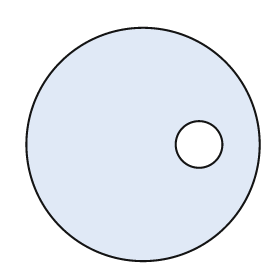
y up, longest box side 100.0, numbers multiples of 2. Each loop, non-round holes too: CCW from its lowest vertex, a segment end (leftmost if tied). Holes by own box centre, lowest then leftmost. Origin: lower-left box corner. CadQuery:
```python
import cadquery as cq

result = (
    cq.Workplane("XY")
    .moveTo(50.0, 50.0)
    .circle(50.0)
    .moveTo(74.0, 50.0)
    .circle(10.0)
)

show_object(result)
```